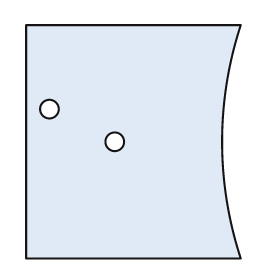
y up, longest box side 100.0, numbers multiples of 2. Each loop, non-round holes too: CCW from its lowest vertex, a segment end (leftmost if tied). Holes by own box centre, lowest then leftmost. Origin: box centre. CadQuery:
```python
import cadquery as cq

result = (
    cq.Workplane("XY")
    .moveTo(-46.0, -50.0)
    .lineTo(46.0, -50.0)
    .threePointArc((38.0, 0.0), (46.0, 50.0))
    .lineTo(-46.0, 50.0)
    .close()
    .moveTo(-8.0, 0.0)
    .circle(4.0)
    .moveTo(-36.0, 14.0)
    .circle(4.0)
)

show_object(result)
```